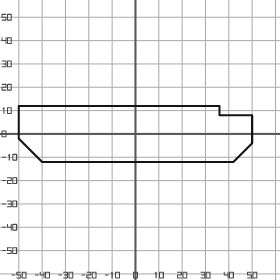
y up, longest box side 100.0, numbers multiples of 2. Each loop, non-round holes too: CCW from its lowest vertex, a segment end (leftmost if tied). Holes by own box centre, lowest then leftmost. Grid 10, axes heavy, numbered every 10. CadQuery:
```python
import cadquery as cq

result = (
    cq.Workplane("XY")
    .moveTo(-40.0, -12.0)
    .lineTo(42.0, -12.0)
    .lineTo(50.0, -4.0)
    .lineTo(50.0, 8.0)
    .lineTo(36.0, 8.0)
    .lineTo(36.0, 12.0)
    .lineTo(-50.0, 12.0)
    .lineTo(-50.0, -2.0)
    .close()
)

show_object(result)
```